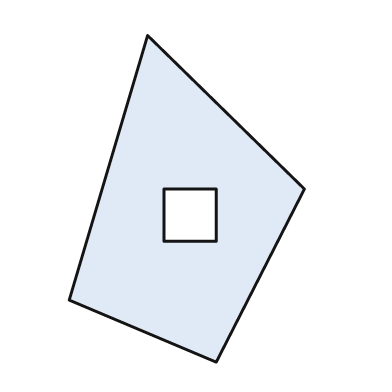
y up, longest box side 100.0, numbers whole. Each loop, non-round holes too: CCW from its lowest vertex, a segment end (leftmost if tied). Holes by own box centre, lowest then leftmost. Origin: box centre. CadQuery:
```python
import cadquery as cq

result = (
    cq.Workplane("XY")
    .moveTo(9.0, -50.0)
    .lineTo(36.0, 3.0)
    .lineTo(-12.0, 50.0)
    .lineTo(-36.0, -31.0)
    .close()
    .moveTo(-7.0, -13.0)
    .lineTo(9.0, -13.0)
    .lineTo(9.0, 3.0)
    .lineTo(-7.0, 3.0)
    .close()
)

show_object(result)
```